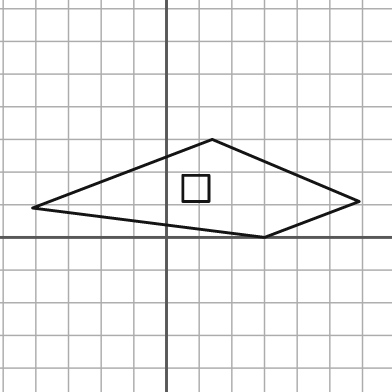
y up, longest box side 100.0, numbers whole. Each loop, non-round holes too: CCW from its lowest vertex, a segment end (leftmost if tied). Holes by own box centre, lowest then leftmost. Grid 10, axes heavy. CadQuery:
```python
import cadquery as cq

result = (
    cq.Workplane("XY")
    .moveTo(30.0, 0.0)
    .lineTo(59.0, 11.0)
    .lineTo(14.0, 30.0)
    .lineTo(-41.0, 9.0)
    .close()
    .moveTo(5.0, 11.0)
    .lineTo(13.0, 11.0)
    .lineTo(13.0, 19.0)
    .lineTo(5.0, 19.0)
    .close()
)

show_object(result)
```